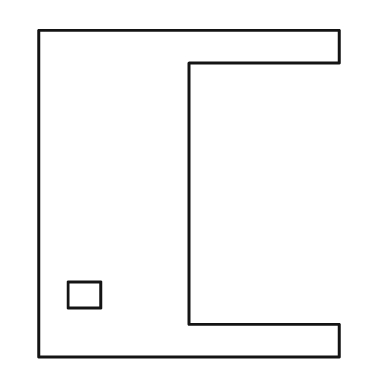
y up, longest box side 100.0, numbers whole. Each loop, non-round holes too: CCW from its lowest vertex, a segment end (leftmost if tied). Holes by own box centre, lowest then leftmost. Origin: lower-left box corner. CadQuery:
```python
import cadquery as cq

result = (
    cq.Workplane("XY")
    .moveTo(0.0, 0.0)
    .lineTo(92.0, 0.0)
    .lineTo(92.0, 10.0)
    .lineTo(46.0, 10.0)
    .lineTo(46.0, 90.0)
    .lineTo(92.0, 90.0)
    .lineTo(92.0, 100.0)
    .lineTo(0.0, 100.0)
    .close()
    .moveTo(9.0, 15.0)
    .lineTo(19.0, 15.0)
    .lineTo(19.0, 23.0)
    .lineTo(9.0, 23.0)
    .close()
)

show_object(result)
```